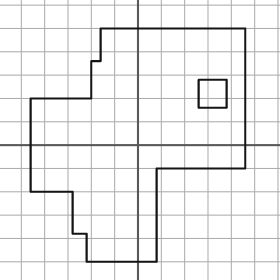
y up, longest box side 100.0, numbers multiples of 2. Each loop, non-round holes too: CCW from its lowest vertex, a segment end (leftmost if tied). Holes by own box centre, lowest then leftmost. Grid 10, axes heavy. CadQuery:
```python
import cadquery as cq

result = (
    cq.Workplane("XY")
    .moveTo(-22.0, -50.0)
    .lineTo(8.0, -50.0)
    .lineTo(8.0, -10.0)
    .lineTo(46.0, -10.0)
    .lineTo(46.0, 50.0)
    .lineTo(-16.0, 50.0)
    .lineTo(-16.0, 36.0)
    .lineTo(-20.0, 36.0)
    .lineTo(-20.0, 20.0)
    .lineTo(-46.0, 20.0)
    .lineTo(-46.0, -20.0)
    .lineTo(-28.0, -20.0)
    .lineTo(-28.0, -38.0)
    .lineTo(-22.0, -38.0)
    .close()
    .moveTo(26.0, 16.0)
    .lineTo(38.0, 16.0)
    .lineTo(38.0, 28.0)
    .lineTo(26.0, 28.0)
    .close()
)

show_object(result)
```